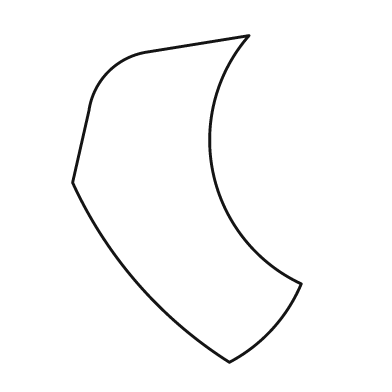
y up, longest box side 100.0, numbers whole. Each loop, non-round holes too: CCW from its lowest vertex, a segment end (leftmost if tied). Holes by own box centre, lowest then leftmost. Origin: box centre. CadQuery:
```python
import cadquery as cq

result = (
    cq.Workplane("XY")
    .moveTo(13.0, -50.0)
    .threePointArc((26.0, -40.0), (35.0, -26.0))
    .threePointArc((8.0, 8.0), (19.0, 50.0))
    .lineTo(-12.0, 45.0)
    .threePointArc((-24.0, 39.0), (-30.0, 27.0))
    .lineTo(-35.0, 5.0)
    .threePointArc((-15.0, -26.0), (13.0, -50.0))
    .close()
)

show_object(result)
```